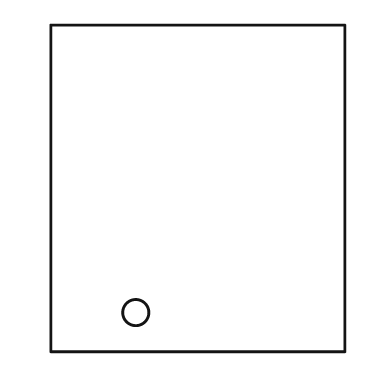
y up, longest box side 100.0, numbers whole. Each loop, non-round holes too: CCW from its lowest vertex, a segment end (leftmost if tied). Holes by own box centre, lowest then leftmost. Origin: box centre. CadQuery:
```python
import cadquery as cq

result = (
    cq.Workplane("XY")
    .moveTo(-45.0, -50.0)
    .lineTo(45.0, -50.0)
    .lineTo(45.0, 50.0)
    .lineTo(-45.0, 50.0)
    .close()
    .moveTo(-19.0, -38.0)
    .circle(4.0)
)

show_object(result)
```